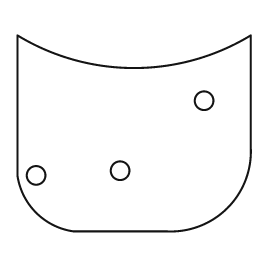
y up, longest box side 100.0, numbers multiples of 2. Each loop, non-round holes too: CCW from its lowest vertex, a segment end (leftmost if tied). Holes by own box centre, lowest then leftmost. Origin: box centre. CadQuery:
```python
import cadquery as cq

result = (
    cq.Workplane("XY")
    .moveTo(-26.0, -42.0)
    .lineTo(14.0, -42.0)
    .threePointArc((40.0, -32.0), (50.0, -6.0))
    .lineTo(50.0, 42.0)
    .threePointArc((0.0, 28.0), (-50.0, 42.0))
    .lineTo(-50.0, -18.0)
    .threePointArc((-42.0, -34.0), (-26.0, -42.0))
    .close()
    .moveTo(-42.0, -18.0)
    .circle(4.0)
    .moveTo(-6.0, -16.0)
    .circle(4.0)
    .moveTo(30.0, 14.0)
    .circle(4.0)
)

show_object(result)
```